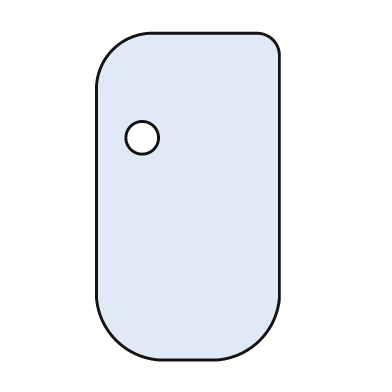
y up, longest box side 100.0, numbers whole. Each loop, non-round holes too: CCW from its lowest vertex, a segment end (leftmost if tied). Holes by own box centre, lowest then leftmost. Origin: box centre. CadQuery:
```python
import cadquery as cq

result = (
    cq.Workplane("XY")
    .moveTo(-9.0, -50.0)
    .lineTo(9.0, -50.0)
    .threePointArc((22.0, -44.0), (28.0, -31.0))
    .lineTo(28.0, 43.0)
    .threePointArc((26.0, 48.0), (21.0, 50.0))
    .lineTo(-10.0, 50.0)
    .threePointArc((-23.0, 45.0), (-28.0, 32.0))
    .lineTo(-28.0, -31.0)
    .threePointArc((-22.0, -44.0), (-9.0, -50.0))
    .close()
    .moveTo(-14.0, 18.0)
    .circle(5.0)
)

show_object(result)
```